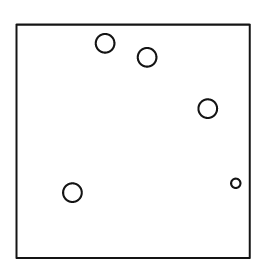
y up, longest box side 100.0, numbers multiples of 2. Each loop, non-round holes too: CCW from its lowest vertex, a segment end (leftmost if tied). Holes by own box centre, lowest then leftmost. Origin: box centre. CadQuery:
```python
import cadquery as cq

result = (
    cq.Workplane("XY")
    .moveTo(-50.0, -50.0)
    .lineTo(50.0, -50.0)
    .lineTo(50.0, 50.0)
    .lineTo(-50.0, 50.0)
    .close()
    .moveTo(-26.0, -22.0)
    .circle(4.0)
    .moveTo(44.0, -18.0)
    .circle(2.0)
    .moveTo(32.0, 14.0)
    .circle(4.0)
    .moveTo(6.0, 36.0)
    .circle(4.0)
    .moveTo(-12.0, 42.0)
    .circle(4.0)
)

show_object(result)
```